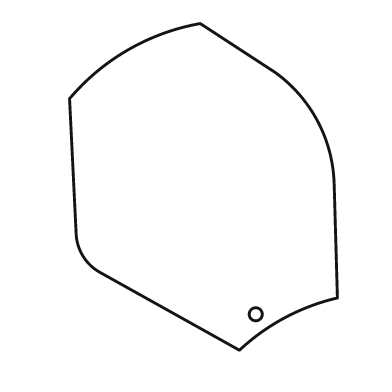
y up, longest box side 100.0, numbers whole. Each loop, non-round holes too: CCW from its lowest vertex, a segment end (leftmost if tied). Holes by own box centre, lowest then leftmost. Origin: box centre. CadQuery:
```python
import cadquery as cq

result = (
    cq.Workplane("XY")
    .moveTo(11.0, -50.0)
    .threePointArc((25.0, -40.0), (41.0, -34.0))
    .lineTo(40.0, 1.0)
    .threePointArc((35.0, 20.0), (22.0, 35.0))
    .lineTo(-1.0, 50.0)
    .threePointArc((-23.0, 42.0), (-41.0, 27.0))
    .lineTo(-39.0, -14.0)
    .threePointArc((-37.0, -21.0), (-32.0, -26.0))
    .close()
    .moveTo(16.0, -39.0)
    .circle(2.0)
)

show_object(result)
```